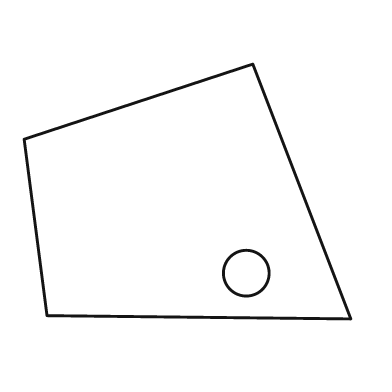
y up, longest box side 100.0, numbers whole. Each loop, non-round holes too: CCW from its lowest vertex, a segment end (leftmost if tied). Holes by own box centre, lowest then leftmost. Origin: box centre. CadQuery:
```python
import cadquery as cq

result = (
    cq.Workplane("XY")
    .moveTo(50.0, -39.0)
    .lineTo(20.0, 39.0)
    .lineTo(-50.0, 16.0)
    .lineTo(-43.0, -38.0)
    .close()
    .moveTo(18.0, -25.0)
    .circle(7.0)
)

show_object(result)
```